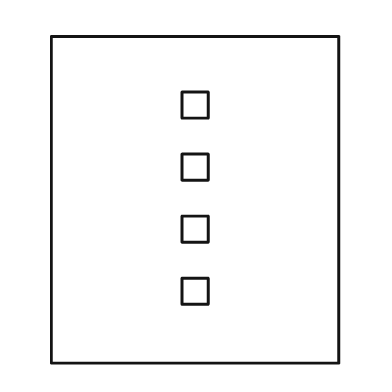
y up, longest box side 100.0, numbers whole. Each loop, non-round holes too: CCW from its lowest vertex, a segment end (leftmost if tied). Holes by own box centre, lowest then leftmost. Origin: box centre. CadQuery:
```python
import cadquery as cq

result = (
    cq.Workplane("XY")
    .moveTo(-44.0, -50.0)
    .lineTo(44.0, -50.0)
    .lineTo(44.0, 50.0)
    .lineTo(-44.0, 50.0)
    .close()
    .moveTo(-4.0, -32.0)
    .lineTo(4.0, -32.0)
    .lineTo(4.0, -24.0)
    .lineTo(-4.0, -24.0)
    .close()
    .moveTo(-4.0, -13.0)
    .lineTo(4.0, -13.0)
    .lineTo(4.0, -5.0)
    .lineTo(-4.0, -5.0)
    .close()
    .moveTo(-4.0, 6.0)
    .lineTo(4.0, 6.0)
    .lineTo(4.0, 14.0)
    .lineTo(-4.0, 14.0)
    .close()
    .moveTo(-4.0, 25.0)
    .lineTo(4.0, 25.0)
    .lineTo(4.0, 33.0)
    .lineTo(-4.0, 33.0)
    .close()
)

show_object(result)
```